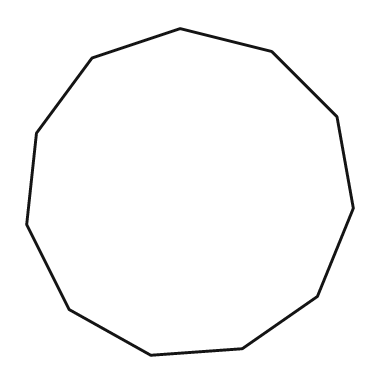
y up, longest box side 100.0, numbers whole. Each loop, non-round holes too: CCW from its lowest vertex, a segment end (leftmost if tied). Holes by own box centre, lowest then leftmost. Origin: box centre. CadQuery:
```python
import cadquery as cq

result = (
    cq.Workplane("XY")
    .moveTo(-12.0, -50.0)
    .lineTo(16.0, -48.0)
    .lineTo(39.0, -32.0)
    .lineTo(50.0, -5.0)
    .lineTo(45.0, 23.0)
    .lineTo(25.0, 43.0)
    .lineTo(-3.0, 50.0)
    .lineTo(-30.0, 41.0)
    .lineTo(-47.0, 18.0)
    .lineTo(-50.0, -10.0)
    .lineTo(-37.0, -36.0)
    .close()
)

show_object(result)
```